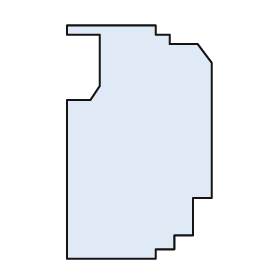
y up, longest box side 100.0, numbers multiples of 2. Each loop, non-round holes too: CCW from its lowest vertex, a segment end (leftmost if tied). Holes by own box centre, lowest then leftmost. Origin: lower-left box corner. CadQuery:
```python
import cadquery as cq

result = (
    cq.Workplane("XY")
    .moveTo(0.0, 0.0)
    .lineTo(38.0, 0.0)
    .lineTo(38.0, 4.0)
    .lineTo(46.0, 4.0)
    .lineTo(46.0, 10.0)
    .lineTo(54.0, 10.0)
    .lineTo(54.0, 26.0)
    .lineTo(62.0, 26.0)
    .lineTo(62.0, 84.0)
    .lineTo(56.0, 92.0)
    .lineTo(44.0, 92.0)
    .lineTo(44.0, 96.0)
    .lineTo(38.0, 96.0)
    .lineTo(38.0, 100.0)
    .lineTo(0.0, 100.0)
    .lineTo(0.0, 96.0)
    .lineTo(14.0, 96.0)
    .lineTo(14.0, 74.0)
    .lineTo(10.0, 68.0)
    .lineTo(0.0, 68.0)
    .close()
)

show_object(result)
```